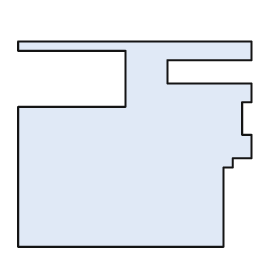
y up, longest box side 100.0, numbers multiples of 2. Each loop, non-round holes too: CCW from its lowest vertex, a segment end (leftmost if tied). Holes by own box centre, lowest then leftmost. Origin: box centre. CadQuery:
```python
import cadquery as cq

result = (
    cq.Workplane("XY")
    .moveTo(-50.0, -44.0)
    .lineTo(38.0, -44.0)
    .lineTo(38.0, -10.0)
    .lineTo(42.0, -10.0)
    .lineTo(42.0, -6.0)
    .lineTo(50.0, -6.0)
    .lineTo(50.0, 4.0)
    .lineTo(46.0, 4.0)
    .lineTo(46.0, 18.0)
    .lineTo(50.0, 18.0)
    .lineTo(50.0, 26.0)
    .lineTo(14.0, 26.0)
    .lineTo(14.0, 36.0)
    .lineTo(50.0, 36.0)
    .lineTo(50.0, 44.0)
    .lineTo(-50.0, 44.0)
    .lineTo(-50.0, 40.0)
    .lineTo(-4.0, 40.0)
    .lineTo(-4.0, 16.0)
    .lineTo(-50.0, 16.0)
    .close()
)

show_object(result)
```